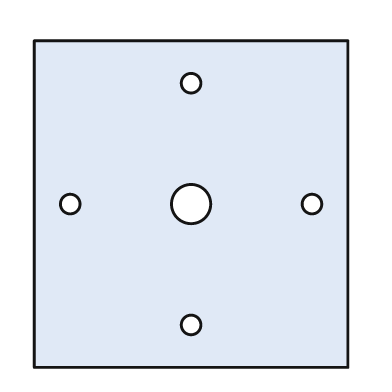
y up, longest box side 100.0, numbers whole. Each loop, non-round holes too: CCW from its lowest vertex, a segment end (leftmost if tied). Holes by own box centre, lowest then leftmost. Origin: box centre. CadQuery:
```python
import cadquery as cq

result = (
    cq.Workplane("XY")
    .moveTo(-48.0, -50.0)
    .lineTo(48.0, -50.0)
    .lineTo(48.0, 50.0)
    .lineTo(-48.0, 50.0)
    .close()
    .moveTo(0.0, -37.0)
    .circle(3.0)
    .moveTo(-37.0, 0.0)
    .circle(3.0)
    .moveTo(0.0, 0.0)
    .circle(6.0)
    .moveTo(37.0, 0.0)
    .circle(3.0)
    .moveTo(0.0, 37.0)
    .circle(3.0)
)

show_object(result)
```